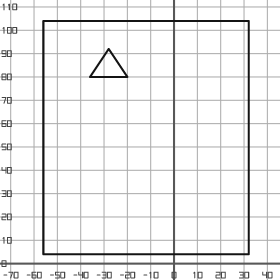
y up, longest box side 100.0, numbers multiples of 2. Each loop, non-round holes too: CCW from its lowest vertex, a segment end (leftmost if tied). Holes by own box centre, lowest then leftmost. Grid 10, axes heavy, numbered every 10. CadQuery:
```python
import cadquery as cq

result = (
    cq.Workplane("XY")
    .moveTo(-56.0, 4.0)
    .lineTo(32.0, 4.0)
    .lineTo(32.0, 104.0)
    .lineTo(-56.0, 104.0)
    .close()
    .moveTo(-36.0, 80.0)
    .lineTo(-20.0, 80.0)
    .lineTo(-28.0, 92.0)
    .close()
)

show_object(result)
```